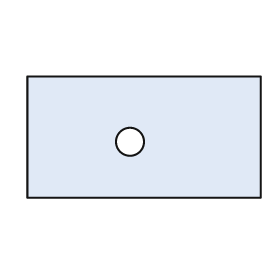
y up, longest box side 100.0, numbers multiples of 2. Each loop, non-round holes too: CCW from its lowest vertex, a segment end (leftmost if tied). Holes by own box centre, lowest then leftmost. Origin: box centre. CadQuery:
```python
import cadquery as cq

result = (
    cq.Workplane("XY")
    .moveTo(-50.0, -26.0)
    .lineTo(50.0, -26.0)
    .lineTo(50.0, 26.0)
    .lineTo(-50.0, 26.0)
    .close()
    .moveTo(-6.0, -2.0)
    .circle(6.0)
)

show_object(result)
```